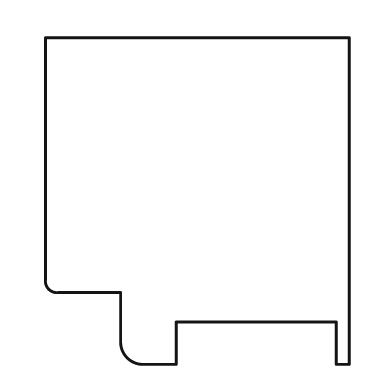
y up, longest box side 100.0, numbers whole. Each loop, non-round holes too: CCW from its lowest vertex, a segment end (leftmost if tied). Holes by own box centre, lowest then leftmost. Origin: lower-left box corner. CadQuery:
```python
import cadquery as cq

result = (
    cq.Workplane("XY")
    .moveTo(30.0, 0.0)
    .lineTo(40.0, 0.0)
    .lineTo(40.0, 13.0)
    .lineTo(89.0, 13.0)
    .lineTo(89.0, 0.0)
    .lineTo(93.0, 0.0)
    .lineTo(93.0, 100.0)
    .lineTo(0.0, 100.0)
    .lineTo(0.0, 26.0)
    .threePointArc((1.0, 23.0), (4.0, 22.0))
    .lineTo(23.0, 22.0)
    .lineTo(23.0, 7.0)
    .threePointArc((25.0, 2.0), (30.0, 0.0))
    .close()
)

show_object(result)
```